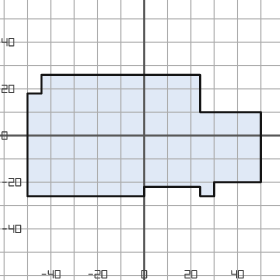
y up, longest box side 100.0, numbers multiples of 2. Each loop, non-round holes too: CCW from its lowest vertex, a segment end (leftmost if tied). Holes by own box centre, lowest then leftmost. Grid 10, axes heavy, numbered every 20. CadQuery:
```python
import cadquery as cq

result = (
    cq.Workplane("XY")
    .moveTo(-50.0, -26.0)
    .lineTo(0.0, -26.0)
    .lineTo(0.0, -22.0)
    .lineTo(24.0, -22.0)
    .lineTo(24.0, -26.0)
    .lineTo(30.0, -26.0)
    .lineTo(30.0, -20.0)
    .lineTo(50.0, -20.0)
    .lineTo(50.0, 10.0)
    .lineTo(24.0, 10.0)
    .lineTo(24.0, 26.0)
    .lineTo(-44.0, 26.0)
    .lineTo(-44.0, 18.0)
    .lineTo(-50.0, 18.0)
    .close()
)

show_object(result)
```